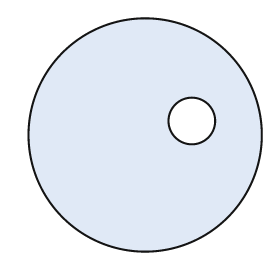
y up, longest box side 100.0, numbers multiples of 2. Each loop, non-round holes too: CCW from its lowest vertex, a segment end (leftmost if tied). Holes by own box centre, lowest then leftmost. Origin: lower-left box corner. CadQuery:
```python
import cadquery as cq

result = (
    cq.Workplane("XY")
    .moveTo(50.0, 50.0)
    .circle(50.0)
    .moveTo(70.0, 56.0)
    .circle(10.0)
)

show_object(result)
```